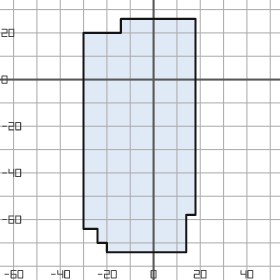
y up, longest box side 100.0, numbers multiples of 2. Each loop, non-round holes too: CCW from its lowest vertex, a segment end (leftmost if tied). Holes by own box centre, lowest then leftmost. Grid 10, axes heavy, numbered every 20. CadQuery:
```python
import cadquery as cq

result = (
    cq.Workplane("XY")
    .moveTo(-20.0, -74.0)
    .lineTo(14.0, -74.0)
    .lineTo(14.0, -58.0)
    .lineTo(18.0, -58.0)
    .lineTo(18.0, 26.0)
    .lineTo(-14.0, 26.0)
    .lineTo(-14.0, 20.0)
    .lineTo(-30.0, 20.0)
    .lineTo(-30.0, -64.0)
    .lineTo(-24.0, -64.0)
    .lineTo(-24.0, -70.0)
    .lineTo(-20.0, -70.0)
    .close()
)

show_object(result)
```